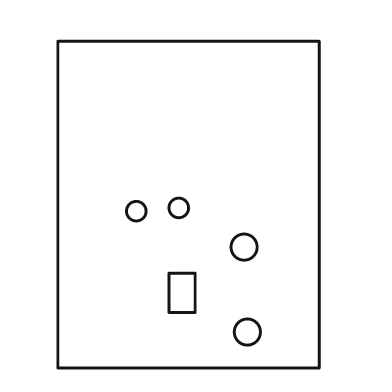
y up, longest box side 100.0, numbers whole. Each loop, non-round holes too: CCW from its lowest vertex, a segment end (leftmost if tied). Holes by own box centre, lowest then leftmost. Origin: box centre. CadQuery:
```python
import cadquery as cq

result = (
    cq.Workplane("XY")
    .moveTo(-40.0, -50.0)
    .lineTo(40.0, -50.0)
    .lineTo(40.0, 50.0)
    .lineTo(-40.0, 50.0)
    .close()
    .moveTo(18.0, -39.0)
    .circle(4.0)
    .moveTo(-6.0, -33.0)
    .lineTo(2.0, -33.0)
    .lineTo(2.0, -21.0)
    .lineTo(-6.0, -21.0)
    .close()
    .moveTo(17.0, -13.0)
    .circle(4.0)
    .moveTo(-16.0, -2.0)
    .circle(3.0)
    .moveTo(-3.0, -1.0)
    .circle(3.0)
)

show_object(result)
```